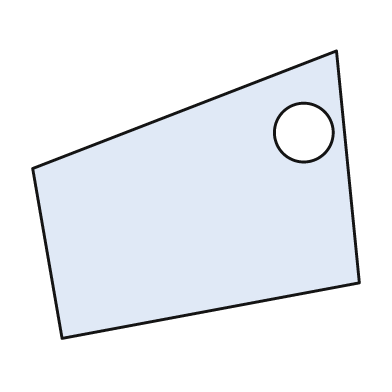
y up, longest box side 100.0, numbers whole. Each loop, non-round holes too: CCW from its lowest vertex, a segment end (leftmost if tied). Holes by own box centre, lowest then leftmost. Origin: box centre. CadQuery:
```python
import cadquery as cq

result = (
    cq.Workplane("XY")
    .moveTo(-41.0, -44.0)
    .lineTo(50.0, -27.0)
    .lineTo(43.0, 44.0)
    .lineTo(-50.0, 8.0)
    .close()
    .moveTo(33.0, 19.0)
    .circle(9.0)
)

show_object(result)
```